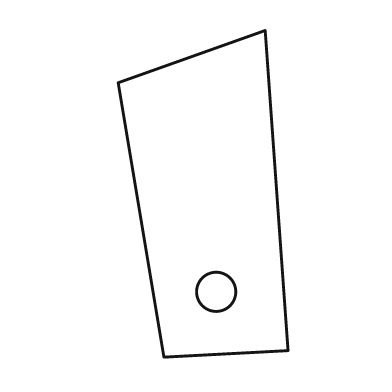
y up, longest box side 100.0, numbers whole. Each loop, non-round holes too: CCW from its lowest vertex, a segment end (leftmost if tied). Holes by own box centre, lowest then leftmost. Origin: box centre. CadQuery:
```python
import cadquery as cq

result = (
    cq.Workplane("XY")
    .moveTo(-12.0, -50.0)
    .lineTo(26.0, -48.0)
    .lineTo(19.0, 50.0)
    .lineTo(-26.0, 34.0)
    .close()
    .moveTo(4.0, -30.0)
    .circle(6.0)
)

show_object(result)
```